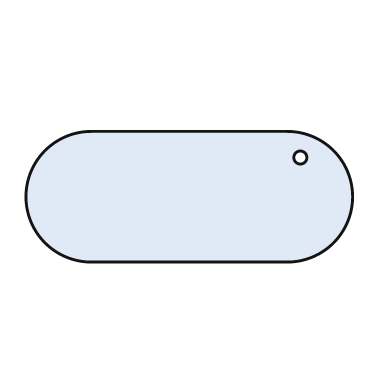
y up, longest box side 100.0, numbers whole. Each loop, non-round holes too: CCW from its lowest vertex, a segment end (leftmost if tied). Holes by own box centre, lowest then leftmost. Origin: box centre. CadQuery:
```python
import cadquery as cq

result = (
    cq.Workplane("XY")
    .moveTo(-30.0, -20.0)
    .lineTo(30.0, -20.0)
    .threePointArc((50.0, 0.0), (30.0, 20.0))
    .lineTo(-30.0, 20.0)
    .threePointArc((-50.0, 0.0), (-30.0, -20.0))
    .close()
    .moveTo(34.0, 12.0)
    .circle(2.0)
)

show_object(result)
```